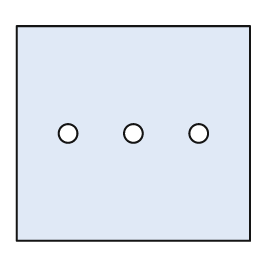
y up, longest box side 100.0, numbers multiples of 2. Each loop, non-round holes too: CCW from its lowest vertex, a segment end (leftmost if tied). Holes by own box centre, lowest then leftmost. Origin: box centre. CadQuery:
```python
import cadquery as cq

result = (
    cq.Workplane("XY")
    .moveTo(-50.0, -46.0)
    .lineTo(50.0, -46.0)
    .lineTo(50.0, 46.0)
    .lineTo(-50.0, 46.0)
    .close()
    .moveTo(-28.0, 0.0)
    .circle(4.0)
    .moveTo(0.0, 0.0)
    .circle(4.0)
    .moveTo(28.0, 0.0)
    .circle(4.0)
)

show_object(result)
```